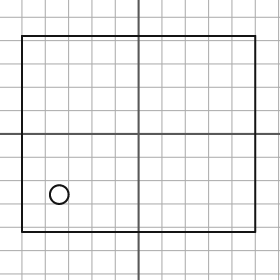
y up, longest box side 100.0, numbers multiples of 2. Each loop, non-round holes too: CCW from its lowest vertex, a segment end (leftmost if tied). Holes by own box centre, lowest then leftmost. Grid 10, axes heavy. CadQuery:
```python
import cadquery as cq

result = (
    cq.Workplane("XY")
    .moveTo(-50.0, -42.0)
    .lineTo(50.0, -42.0)
    .lineTo(50.0, 42.0)
    .lineTo(-50.0, 42.0)
    .close()
    .moveTo(-34.0, -26.0)
    .circle(4.0)
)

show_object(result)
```